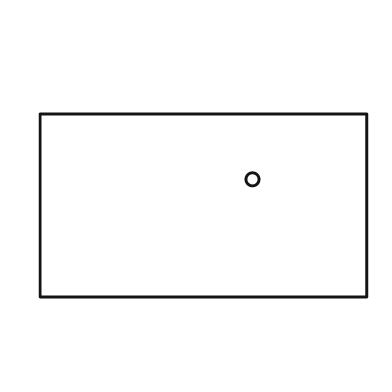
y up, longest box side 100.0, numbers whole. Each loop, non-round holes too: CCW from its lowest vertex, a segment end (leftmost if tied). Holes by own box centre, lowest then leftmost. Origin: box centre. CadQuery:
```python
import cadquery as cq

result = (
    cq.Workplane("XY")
    .moveTo(-50.0, -28.0)
    .lineTo(50.0, -28.0)
    .lineTo(50.0, 28.0)
    .lineTo(-50.0, 28.0)
    .close()
    .moveTo(15.0, 8.0)
    .circle(2.0)
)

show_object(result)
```